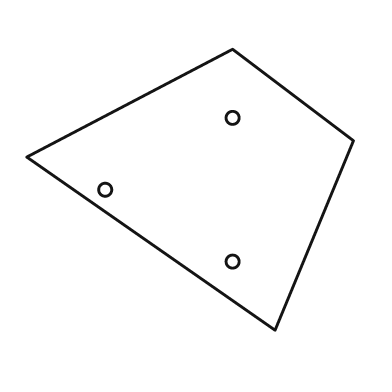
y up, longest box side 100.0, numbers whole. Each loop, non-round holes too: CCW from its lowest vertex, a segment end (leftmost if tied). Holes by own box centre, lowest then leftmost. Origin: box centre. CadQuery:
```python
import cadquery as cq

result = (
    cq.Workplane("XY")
    .moveTo(26.0, -43.0)
    .lineTo(50.0, 15.0)
    .lineTo(13.0, 43.0)
    .lineTo(-50.0, 10.0)
    .close()
    .moveTo(13.0, -22.0)
    .circle(2.0)
    .moveTo(-26.0, 0.0)
    .circle(2.0)
    .moveTo(13.0, 22.0)
    .circle(2.0)
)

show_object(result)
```